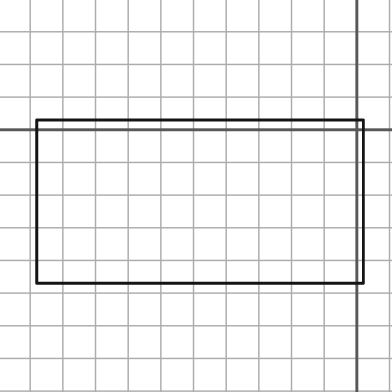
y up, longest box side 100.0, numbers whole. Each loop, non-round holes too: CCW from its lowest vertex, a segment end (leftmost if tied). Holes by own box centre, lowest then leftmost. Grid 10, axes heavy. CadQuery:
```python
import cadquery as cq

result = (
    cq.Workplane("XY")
    .moveTo(-98.0, -47.0)
    .lineTo(2.0, -47.0)
    .lineTo(2.0, 3.0)
    .lineTo(-98.0, 3.0)
    .close()
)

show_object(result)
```